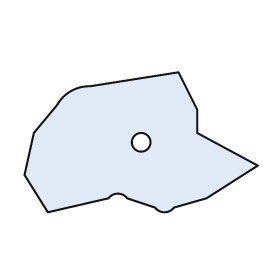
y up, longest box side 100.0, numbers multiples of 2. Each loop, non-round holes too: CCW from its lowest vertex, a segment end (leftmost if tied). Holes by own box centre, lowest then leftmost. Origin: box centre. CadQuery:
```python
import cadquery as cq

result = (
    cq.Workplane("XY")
    .moveTo(-40.0, -30.0)
    .lineTo(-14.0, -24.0)
    .threePointArc((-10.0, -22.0), (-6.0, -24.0))
    .lineTo(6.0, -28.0)
    .threePointArc((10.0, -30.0), (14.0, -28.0))
    .lineTo(28.0, -24.0)
    .lineTo(50.0, -10.0)
    .lineTo(24.0, 4.0)
    .lineTo(24.0, 14.0)
    .lineTo(16.0, 30.0)
    .lineTo(-22.0, 24.0)
    .threePointArc((-30.0, 22.0), (-36.0, 16.0))
    .lineTo(-46.0, 4.0)
    .lineTo(-50.0, -14.0)
    .close()
    .moveTo(0.0, 0.0)
    .circle(4.0)
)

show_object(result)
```